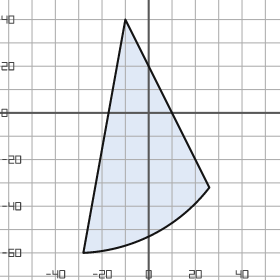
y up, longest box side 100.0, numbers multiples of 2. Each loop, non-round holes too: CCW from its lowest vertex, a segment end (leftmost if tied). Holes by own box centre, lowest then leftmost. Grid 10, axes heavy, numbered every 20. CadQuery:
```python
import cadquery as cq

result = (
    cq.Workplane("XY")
    .moveTo(-28.0, -60.0)
    .threePointArc((2.0, -52.0), (26.0, -32.0))
    .lineTo(-10.0, 40.0)
    .close()
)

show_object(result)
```